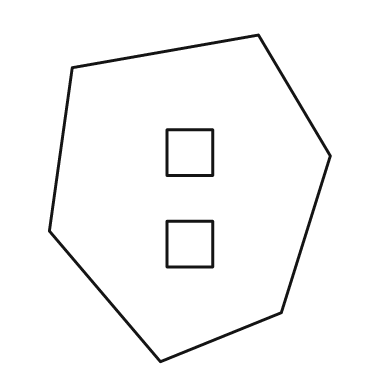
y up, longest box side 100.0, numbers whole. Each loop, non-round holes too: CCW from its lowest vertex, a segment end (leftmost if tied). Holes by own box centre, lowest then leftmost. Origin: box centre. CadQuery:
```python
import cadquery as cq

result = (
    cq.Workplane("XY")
    .moveTo(-9.0, -50.0)
    .lineTo(28.0, -35.0)
    .lineTo(43.0, 13.0)
    .lineTo(21.0, 50.0)
    .lineTo(-36.0, 40.0)
    .lineTo(-43.0, -10.0)
    .close()
    .moveTo(-7.0, -21.0)
    .lineTo(7.0, -21.0)
    .lineTo(7.0, -7.0)
    .lineTo(-7.0, -7.0)
    .close()
    .moveTo(-7.0, 7.0)
    .lineTo(7.0, 7.0)
    .lineTo(7.0, 21.0)
    .lineTo(-7.0, 21.0)
    .close()
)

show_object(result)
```